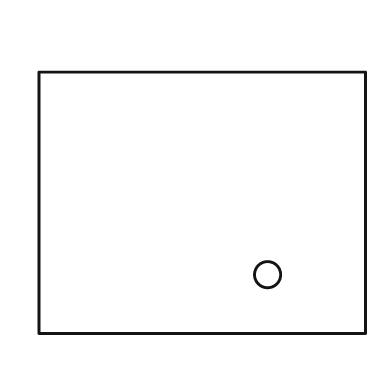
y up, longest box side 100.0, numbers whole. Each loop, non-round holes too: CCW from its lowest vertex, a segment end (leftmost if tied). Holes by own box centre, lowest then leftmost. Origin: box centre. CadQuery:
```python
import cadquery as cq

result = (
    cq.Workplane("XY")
    .moveTo(-50.0, -40.0)
    .lineTo(50.0, -40.0)
    .lineTo(50.0, 40.0)
    .lineTo(-50.0, 40.0)
    .close()
    .moveTo(20.0, -22.0)
    .circle(4.0)
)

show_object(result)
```